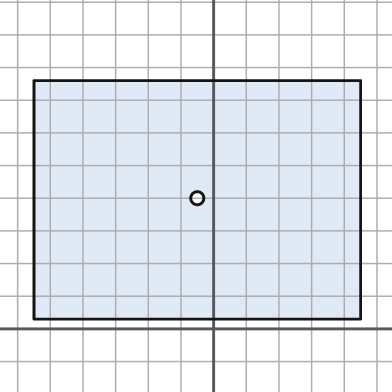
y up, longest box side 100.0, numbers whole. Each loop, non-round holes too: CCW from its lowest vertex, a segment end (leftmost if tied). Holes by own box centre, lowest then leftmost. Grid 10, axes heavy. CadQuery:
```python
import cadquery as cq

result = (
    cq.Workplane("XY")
    .moveTo(-55.0, 3.0)
    .lineTo(45.0, 3.0)
    .lineTo(45.0, 76.0)
    .lineTo(-55.0, 76.0)
    .close()
    .moveTo(-5.0, 40.0)
    .circle(2.0)
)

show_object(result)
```